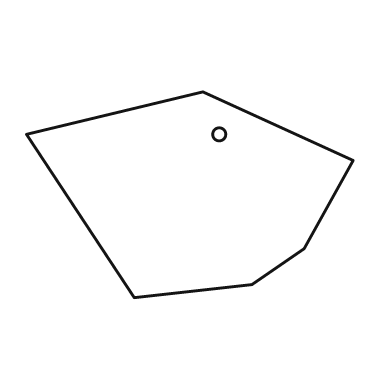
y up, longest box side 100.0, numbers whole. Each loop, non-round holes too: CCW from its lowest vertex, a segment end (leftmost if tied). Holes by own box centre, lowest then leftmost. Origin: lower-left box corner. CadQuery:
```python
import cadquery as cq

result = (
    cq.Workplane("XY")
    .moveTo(33.0, 0.0)
    .lineTo(69.0, 4.0)
    .lineTo(85.0, 15.0)
    .lineTo(100.0, 42.0)
    .lineTo(54.0, 63.0)
    .lineTo(0.0, 50.0)
    .close()
    .moveTo(59.0, 50.0)
    .circle(2.0)
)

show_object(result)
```